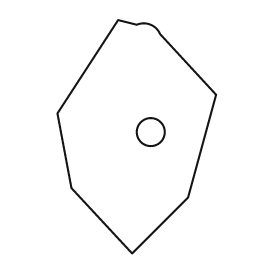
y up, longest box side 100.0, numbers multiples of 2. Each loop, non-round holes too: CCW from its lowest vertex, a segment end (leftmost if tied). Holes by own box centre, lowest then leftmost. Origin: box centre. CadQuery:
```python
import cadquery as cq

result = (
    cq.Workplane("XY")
    .moveTo(-2.0, -50.0)
    .lineTo(22.0, -26.0)
    .lineTo(34.0, 18.0)
    .lineTo(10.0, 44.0)
    .threePointArc((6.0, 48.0), (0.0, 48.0))
    .lineTo(-8.0, 50.0)
    .lineTo(-34.0, 10.0)
    .lineTo(-28.0, -22.0)
    .close()
    .moveTo(6.0, 2.0)
    .circle(6.0)
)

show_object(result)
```